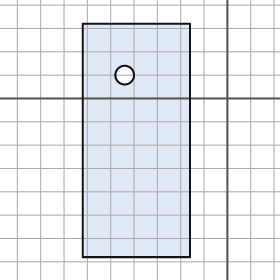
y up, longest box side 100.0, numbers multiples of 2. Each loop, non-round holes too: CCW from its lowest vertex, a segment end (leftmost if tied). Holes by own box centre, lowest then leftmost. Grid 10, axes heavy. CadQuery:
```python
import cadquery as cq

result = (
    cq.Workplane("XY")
    .moveTo(-62.0, -68.0)
    .lineTo(-16.0, -68.0)
    .lineTo(-16.0, 32.0)
    .lineTo(-62.0, 32.0)
    .close()
    .moveTo(-44.0, 10.0)
    .circle(4.0)
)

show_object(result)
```